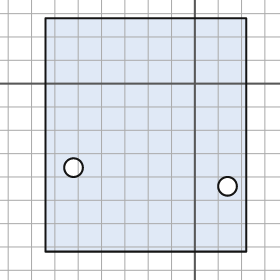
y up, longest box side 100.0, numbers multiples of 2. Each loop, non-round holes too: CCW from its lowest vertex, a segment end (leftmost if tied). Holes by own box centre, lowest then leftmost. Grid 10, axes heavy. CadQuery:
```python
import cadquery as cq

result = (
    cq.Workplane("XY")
    .moveTo(-64.0, -72.0)
    .lineTo(22.0, -72.0)
    .lineTo(22.0, 28.0)
    .lineTo(-64.0, 28.0)
    .close()
    .moveTo(14.0, -44.0)
    .circle(4.0)
    .moveTo(-52.0, -36.0)
    .circle(4.0)
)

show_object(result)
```